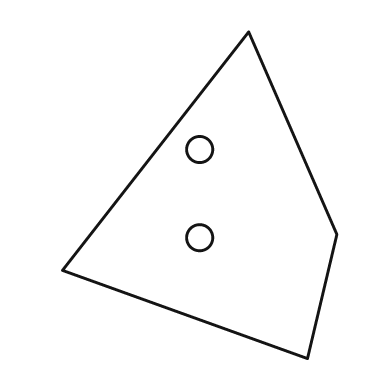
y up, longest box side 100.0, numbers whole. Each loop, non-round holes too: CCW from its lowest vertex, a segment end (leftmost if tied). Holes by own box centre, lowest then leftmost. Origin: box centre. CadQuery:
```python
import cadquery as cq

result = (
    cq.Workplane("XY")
    .moveTo(33.0, -50.0)
    .lineTo(42.0, -12.0)
    .lineTo(15.0, 50.0)
    .lineTo(-42.0, -23.0)
    .close()
    .moveTo(0.0, -13.0)
    .circle(4.0)
    .moveTo(0.0, 14.0)
    .circle(4.0)
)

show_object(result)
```